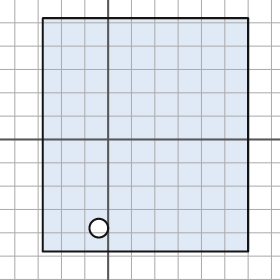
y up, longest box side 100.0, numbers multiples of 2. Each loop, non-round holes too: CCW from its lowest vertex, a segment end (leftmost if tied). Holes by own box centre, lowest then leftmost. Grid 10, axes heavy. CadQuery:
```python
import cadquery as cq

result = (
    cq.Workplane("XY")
    .moveTo(-28.0, -48.0)
    .lineTo(60.0, -48.0)
    .lineTo(60.0, 52.0)
    .lineTo(-28.0, 52.0)
    .close()
    .moveTo(-4.0, -38.0)
    .circle(4.0)
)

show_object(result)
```